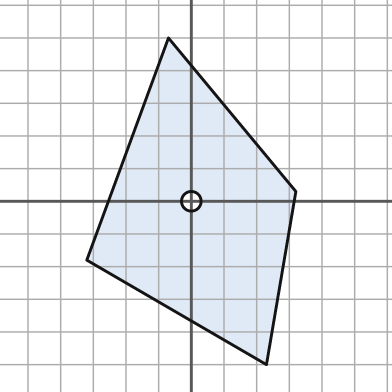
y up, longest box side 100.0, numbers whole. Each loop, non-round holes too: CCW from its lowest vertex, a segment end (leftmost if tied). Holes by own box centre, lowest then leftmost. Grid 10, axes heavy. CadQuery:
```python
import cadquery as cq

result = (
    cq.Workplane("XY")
    .moveTo(23.0, -50.0)
    .lineTo(32.0, 3.0)
    .lineTo(-7.0, 50.0)
    .lineTo(-32.0, -18.0)
    .close()
    .moveTo(0.0, 0.0)
    .circle(3.0)
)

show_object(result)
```